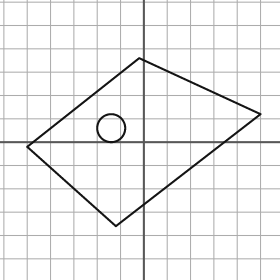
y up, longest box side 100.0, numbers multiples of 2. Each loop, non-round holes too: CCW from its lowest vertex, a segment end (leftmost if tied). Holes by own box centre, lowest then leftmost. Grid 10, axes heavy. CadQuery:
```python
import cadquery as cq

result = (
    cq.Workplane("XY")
    .moveTo(-12.0, -36.0)
    .lineTo(50.0, 12.0)
    .lineTo(-2.0, 36.0)
    .lineTo(-50.0, -2.0)
    .close()
    .moveTo(-14.0, 6.0)
    .circle(6.0)
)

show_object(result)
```